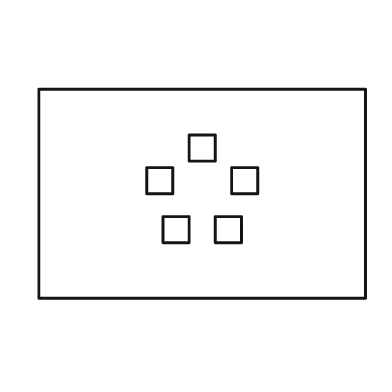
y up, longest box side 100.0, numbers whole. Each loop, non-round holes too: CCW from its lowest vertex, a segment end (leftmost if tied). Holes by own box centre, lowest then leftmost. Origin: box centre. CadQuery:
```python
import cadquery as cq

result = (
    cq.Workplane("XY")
    .moveTo(-50.0, -32.0)
    .lineTo(50.0, -32.0)
    .lineTo(50.0, 32.0)
    .lineTo(-50.0, 32.0)
    .close()
    .moveTo(-12.0, -15.0)
    .lineTo(-4.0, -15.0)
    .lineTo(-4.0, -7.0)
    .lineTo(-12.0, -7.0)
    .close()
    .moveTo(4.0, -15.0)
    .lineTo(12.0, -15.0)
    .lineTo(12.0, -7.0)
    .lineTo(4.0, -7.0)
    .close()
    .moveTo(-17.0, 0.0)
    .lineTo(-9.0, 0.0)
    .lineTo(-9.0, 8.0)
    .lineTo(-17.0, 8.0)
    .close()
    .moveTo(9.0, 0.0)
    .lineTo(17.0, 0.0)
    .lineTo(17.0, 8.0)
    .lineTo(9.0, 8.0)
    .close()
    .moveTo(-4.0, 10.0)
    .lineTo(4.0, 10.0)
    .lineTo(4.0, 18.0)
    .lineTo(-4.0, 18.0)
    .close()
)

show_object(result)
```